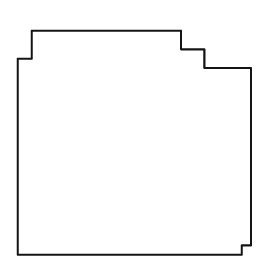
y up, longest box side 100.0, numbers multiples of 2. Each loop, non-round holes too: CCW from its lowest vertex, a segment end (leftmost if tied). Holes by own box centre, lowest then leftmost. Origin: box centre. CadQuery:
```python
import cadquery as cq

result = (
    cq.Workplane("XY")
    .moveTo(-50.0, -48.0)
    .lineTo(46.0, -48.0)
    .lineTo(46.0, -44.0)
    .lineTo(50.0, -44.0)
    .lineTo(50.0, 32.0)
    .lineTo(30.0, 32.0)
    .lineTo(30.0, 40.0)
    .lineTo(20.0, 40.0)
    .lineTo(20.0, 48.0)
    .lineTo(-44.0, 48.0)
    .lineTo(-44.0, 36.0)
    .lineTo(-50.0, 36.0)
    .close()
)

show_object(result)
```